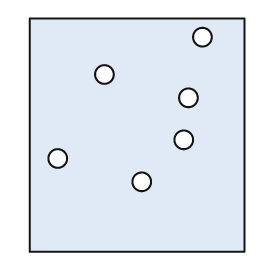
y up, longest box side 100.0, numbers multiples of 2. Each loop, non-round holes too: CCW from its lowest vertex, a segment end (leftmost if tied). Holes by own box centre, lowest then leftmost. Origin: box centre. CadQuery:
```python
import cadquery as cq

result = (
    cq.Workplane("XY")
    .moveTo(-46.0, -50.0)
    .lineTo(46.0, -50.0)
    .lineTo(46.0, 50.0)
    .lineTo(-46.0, 50.0)
    .close()
    .moveTo(2.0, -20.0)
    .circle(4.0)
    .moveTo(-34.0, -10.0)
    .circle(4.0)
    .moveTo(20.0, -2.0)
    .circle(4.0)
    .moveTo(22.0, 16.0)
    .circle(4.0)
    .moveTo(-14.0, 26.0)
    .circle(4.0)
    .moveTo(28.0, 42.0)
    .circle(4.0)
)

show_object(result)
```